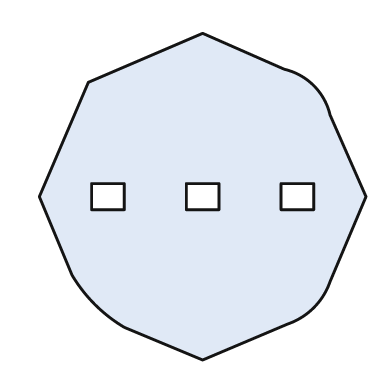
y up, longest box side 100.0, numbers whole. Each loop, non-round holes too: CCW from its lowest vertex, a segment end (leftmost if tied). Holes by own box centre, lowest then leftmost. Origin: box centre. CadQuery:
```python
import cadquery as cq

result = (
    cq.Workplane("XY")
    .moveTo(0.0, -50.0)
    .lineTo(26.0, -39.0)
    .threePointArc((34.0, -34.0), (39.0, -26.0))
    .lineTo(50.0, 0.0)
    .lineTo(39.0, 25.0)
    .threePointArc((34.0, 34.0), (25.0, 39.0))
    .lineTo(0.0, 50.0)
    .lineTo(-35.0, 35.0)
    .lineTo(-50.0, 0.0)
    .lineTo(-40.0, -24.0)
    .threePointArc((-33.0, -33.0), (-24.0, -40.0))
    .close()
    .moveTo(-34.0, -4.0)
    .lineTo(-24.0, -4.0)
    .lineTo(-24.0, 4.0)
    .lineTo(-34.0, 4.0)
    .close()
    .moveTo(-5.0, -4.0)
    .lineTo(5.0, -4.0)
    .lineTo(5.0, 4.0)
    .lineTo(-5.0, 4.0)
    .close()
    .moveTo(24.0, -4.0)
    .lineTo(34.0, -4.0)
    .lineTo(34.0, 4.0)
    .lineTo(24.0, 4.0)
    .close()
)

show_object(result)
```